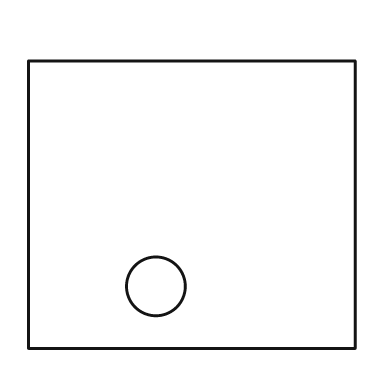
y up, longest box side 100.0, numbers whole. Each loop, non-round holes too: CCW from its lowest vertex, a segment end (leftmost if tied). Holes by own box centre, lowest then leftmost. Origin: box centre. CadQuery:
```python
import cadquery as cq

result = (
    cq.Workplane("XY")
    .moveTo(-50.0, -44.0)
    .lineTo(50.0, -44.0)
    .lineTo(50.0, 44.0)
    .lineTo(-50.0, 44.0)
    .close()
    .moveTo(-11.0, -25.0)
    .circle(9.0)
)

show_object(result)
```